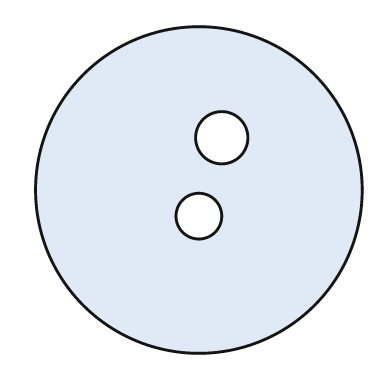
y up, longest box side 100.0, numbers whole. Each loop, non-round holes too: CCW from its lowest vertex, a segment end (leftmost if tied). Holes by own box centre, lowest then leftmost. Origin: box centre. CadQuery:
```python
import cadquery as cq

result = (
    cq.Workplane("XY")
    .moveTo(0.0, 0.0)
    .circle(50.0)
    .moveTo(0.0, -8.0)
    .circle(7.0)
    .moveTo(7.0, 16.0)
    .circle(8.0)
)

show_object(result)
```